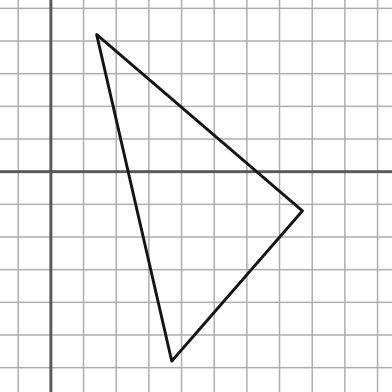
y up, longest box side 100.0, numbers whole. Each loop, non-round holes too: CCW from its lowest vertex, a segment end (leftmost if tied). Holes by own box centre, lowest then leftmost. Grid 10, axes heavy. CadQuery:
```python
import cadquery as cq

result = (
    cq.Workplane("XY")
    .moveTo(37.0, -58.0)
    .lineTo(77.0, -12.0)
    .lineTo(14.0, 42.0)
    .close()
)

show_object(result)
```